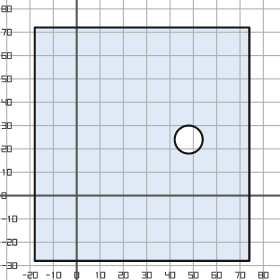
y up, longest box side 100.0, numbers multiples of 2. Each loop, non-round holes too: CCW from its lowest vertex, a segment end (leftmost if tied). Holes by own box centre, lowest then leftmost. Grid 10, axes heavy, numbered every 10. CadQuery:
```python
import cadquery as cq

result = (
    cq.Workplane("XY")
    .moveTo(-18.0, -28.0)
    .lineTo(74.0, -28.0)
    .lineTo(74.0, 72.0)
    .lineTo(-18.0, 72.0)
    .close()
    .moveTo(48.0, 24.0)
    .circle(6.0)
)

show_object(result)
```